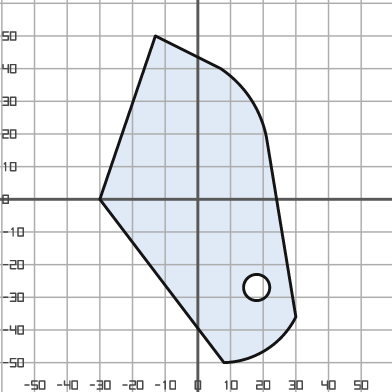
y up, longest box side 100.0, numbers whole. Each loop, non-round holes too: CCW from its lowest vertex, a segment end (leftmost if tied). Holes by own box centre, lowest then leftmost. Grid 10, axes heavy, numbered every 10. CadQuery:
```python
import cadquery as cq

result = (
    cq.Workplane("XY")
    .moveTo(8.0, -50.0)
    .threePointArc((21.0, -46.0), (30.0, -36.0))
    .lineTo(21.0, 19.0)
    .threePointArc((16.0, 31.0), (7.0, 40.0))
    .lineTo(-13.0, 50.0)
    .lineTo(-30.0, 0.0)
    .close()
    .moveTo(18.0, -27.0)
    .circle(4.0)
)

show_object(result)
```